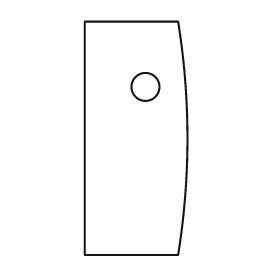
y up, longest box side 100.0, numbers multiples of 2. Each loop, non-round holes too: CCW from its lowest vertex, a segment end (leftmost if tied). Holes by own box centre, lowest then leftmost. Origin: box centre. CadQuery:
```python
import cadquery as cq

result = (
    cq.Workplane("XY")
    .moveTo(-22.0, -50.0)
    .lineTo(18.0, -50.0)
    .threePointArc((22.0, 0.0), (18.0, 50.0))
    .lineTo(-22.0, 50.0)
    .close()
    .moveTo(4.0, 22.0)
    .circle(6.0)
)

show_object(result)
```